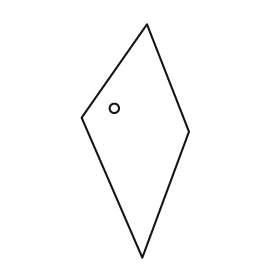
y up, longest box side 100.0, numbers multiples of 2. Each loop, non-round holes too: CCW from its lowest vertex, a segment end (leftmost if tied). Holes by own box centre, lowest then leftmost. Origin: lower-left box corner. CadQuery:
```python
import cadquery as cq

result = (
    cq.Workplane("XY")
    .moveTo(26.0, 0.0)
    .lineTo(46.0, 54.0)
    .lineTo(28.0, 100.0)
    .lineTo(0.0, 60.0)
    .close()
    .moveTo(14.0, 64.0)
    .circle(2.0)
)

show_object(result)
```